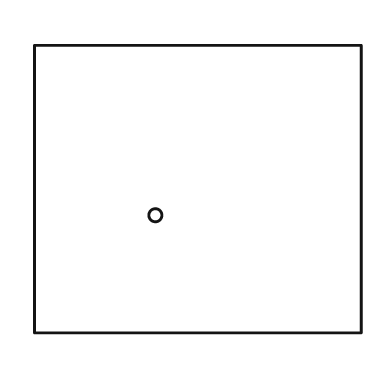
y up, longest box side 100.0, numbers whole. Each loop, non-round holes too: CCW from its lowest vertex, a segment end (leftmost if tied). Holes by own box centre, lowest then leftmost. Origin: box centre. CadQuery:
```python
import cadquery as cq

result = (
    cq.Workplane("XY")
    .moveTo(-50.0, -44.0)
    .lineTo(50.0, -44.0)
    .lineTo(50.0, 44.0)
    .lineTo(-50.0, 44.0)
    .close()
    .moveTo(-13.0, -8.0)
    .circle(2.0)
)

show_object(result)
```